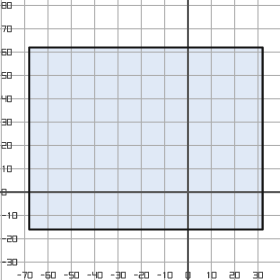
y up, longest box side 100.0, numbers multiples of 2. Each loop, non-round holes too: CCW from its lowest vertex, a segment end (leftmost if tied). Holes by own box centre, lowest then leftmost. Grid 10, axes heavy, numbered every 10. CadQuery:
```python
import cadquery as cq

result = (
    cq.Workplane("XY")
    .moveTo(-68.0, -16.0)
    .lineTo(32.0, -16.0)
    .lineTo(32.0, 62.0)
    .lineTo(-68.0, 62.0)
    .close()
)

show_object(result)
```